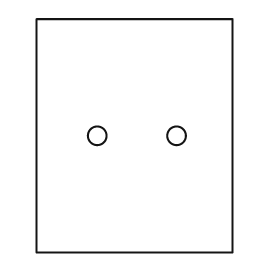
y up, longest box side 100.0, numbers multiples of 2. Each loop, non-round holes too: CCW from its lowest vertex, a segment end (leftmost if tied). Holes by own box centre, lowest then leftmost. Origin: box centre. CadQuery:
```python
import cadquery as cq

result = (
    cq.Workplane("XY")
    .moveTo(-42.0, -50.0)
    .lineTo(42.0, -50.0)
    .lineTo(42.0, 50.0)
    .lineTo(-42.0, 50.0)
    .close()
    .moveTo(-16.0, 0.0)
    .circle(4.0)
    .moveTo(18.0, 0.0)
    .circle(4.0)
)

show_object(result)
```